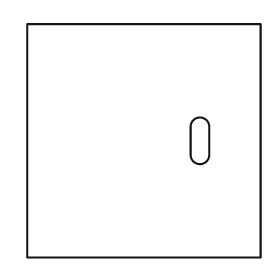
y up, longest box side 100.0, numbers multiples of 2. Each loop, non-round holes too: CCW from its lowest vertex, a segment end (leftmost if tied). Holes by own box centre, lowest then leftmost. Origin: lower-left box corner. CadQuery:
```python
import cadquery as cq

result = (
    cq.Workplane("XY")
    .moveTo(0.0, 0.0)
    .lineTo(100.0, 0.0)
    .lineTo(100.0, 100.0)
    .lineTo(0.0, 100.0)
    .close()
    .moveTo(70.0, 44.0)
    .threePointArc((74.0, 40.0), (78.0, 44.0))
    .lineTo(78.0, 56.0)
    .threePointArc((74.0, 60.0), (70.0, 56.0))
    .close()
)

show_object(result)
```